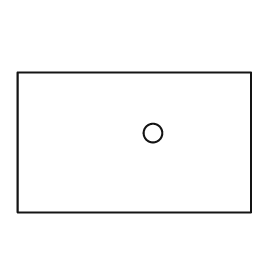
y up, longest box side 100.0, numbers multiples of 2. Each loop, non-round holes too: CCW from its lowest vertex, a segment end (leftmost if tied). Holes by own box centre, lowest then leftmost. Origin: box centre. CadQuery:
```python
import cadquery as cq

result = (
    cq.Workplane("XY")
    .moveTo(-50.0, -30.0)
    .lineTo(50.0, -30.0)
    .lineTo(50.0, 30.0)
    .lineTo(-50.0, 30.0)
    .close()
    .moveTo(8.0, 4.0)
    .circle(4.0)
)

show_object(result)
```